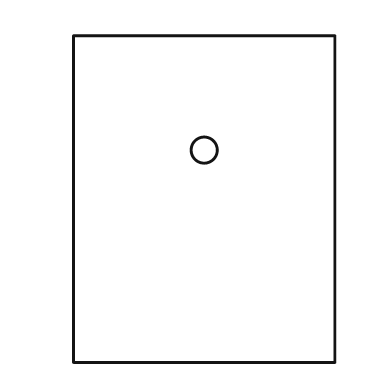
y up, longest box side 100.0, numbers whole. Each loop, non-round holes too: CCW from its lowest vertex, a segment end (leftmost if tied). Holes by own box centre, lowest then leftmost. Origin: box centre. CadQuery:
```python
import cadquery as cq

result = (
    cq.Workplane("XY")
    .moveTo(-40.0, -50.0)
    .lineTo(40.0, -50.0)
    .lineTo(40.0, 50.0)
    .lineTo(-40.0, 50.0)
    .close()
    .moveTo(0.0, 15.0)
    .circle(4.0)
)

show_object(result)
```